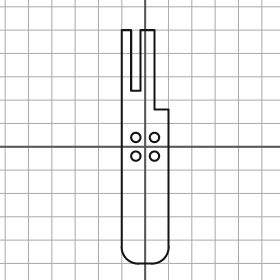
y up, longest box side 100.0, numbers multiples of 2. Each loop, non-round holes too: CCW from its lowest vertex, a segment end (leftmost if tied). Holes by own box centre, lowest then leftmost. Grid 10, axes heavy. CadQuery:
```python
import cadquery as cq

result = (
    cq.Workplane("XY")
    .moveTo(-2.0, -50.0)
    .lineTo(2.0, -50.0)
    .threePointArc((8.0, -48.0), (10.0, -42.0))
    .lineTo(10.0, 16.0)
    .lineTo(4.0, 16.0)
    .lineTo(4.0, 50.0)
    .lineTo(-2.0, 50.0)
    .lineTo(-2.0, 24.0)
    .lineTo(-6.0, 24.0)
    .lineTo(-6.0, 50.0)
    .lineTo(-10.0, 50.0)
    .lineTo(-10.0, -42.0)
    .threePointArc((-8.0, -48.0), (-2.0, -50.0))
    .close()
    .moveTo(-4.0, -4.0)
    .circle(2.0)
    .moveTo(4.0, -4.0)
    .circle(2.0)
    .moveTo(-4.0, 4.0)
    .circle(2.0)
    .moveTo(4.0, 4.0)
    .circle(2.0)
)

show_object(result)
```